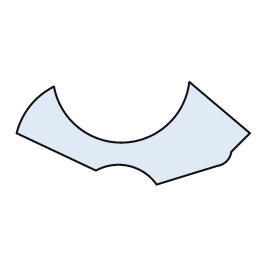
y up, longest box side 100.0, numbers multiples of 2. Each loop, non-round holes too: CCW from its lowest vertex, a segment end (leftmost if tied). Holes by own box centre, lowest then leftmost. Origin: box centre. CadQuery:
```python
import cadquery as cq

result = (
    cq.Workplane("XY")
    .moveTo(10.0, -22.0)
    .lineTo(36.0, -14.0)
    .threePointArc((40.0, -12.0), (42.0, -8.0))
    .lineTo(50.0, 0.0)
    .lineTo(24.0, 22.0)
    .threePointArc((-4.0, -4.0), (-34.0, 20.0))
    .threePointArc((-44.0, 12.0), (-50.0, 0.0))
    .lineTo(-16.0, -16.0)
    .threePointArc((-2.0, -14.0), (10.0, -22.0))
    .close()
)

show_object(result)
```